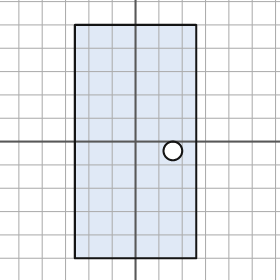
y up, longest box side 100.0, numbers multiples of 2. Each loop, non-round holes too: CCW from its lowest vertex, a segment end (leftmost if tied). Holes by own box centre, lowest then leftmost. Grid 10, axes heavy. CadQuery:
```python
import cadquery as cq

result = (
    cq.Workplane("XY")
    .moveTo(-26.0, -50.0)
    .lineTo(26.0, -50.0)
    .lineTo(26.0, 50.0)
    .lineTo(-26.0, 50.0)
    .close()
    .moveTo(16.0, -4.0)
    .circle(4.0)
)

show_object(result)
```